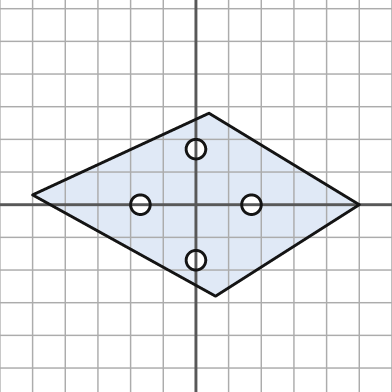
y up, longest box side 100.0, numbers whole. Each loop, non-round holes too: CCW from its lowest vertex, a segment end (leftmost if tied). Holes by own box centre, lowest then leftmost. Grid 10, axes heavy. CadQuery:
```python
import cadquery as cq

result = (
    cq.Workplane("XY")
    .moveTo(6.0, -28.0)
    .lineTo(50.0, 0.0)
    .lineTo(4.0, 28.0)
    .lineTo(-50.0, 3.0)
    .close()
    .moveTo(0.0, -17.0)
    .circle(3.0)
    .moveTo(-17.0, 0.0)
    .circle(3.0)
    .moveTo(17.0, 0.0)
    .circle(3.0)
    .moveTo(0.0, 17.0)
    .circle(3.0)
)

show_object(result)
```